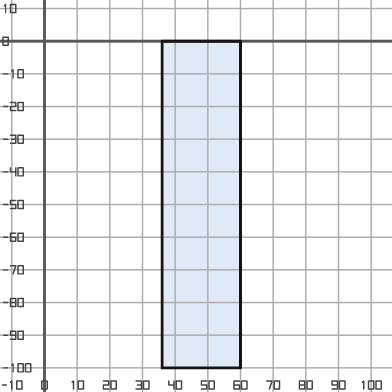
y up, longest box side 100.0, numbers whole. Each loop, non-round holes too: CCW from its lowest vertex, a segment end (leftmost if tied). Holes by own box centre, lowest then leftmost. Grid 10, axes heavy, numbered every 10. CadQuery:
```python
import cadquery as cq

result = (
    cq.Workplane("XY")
    .moveTo(36.0, -100.0)
    .lineTo(60.0, -100.0)
    .lineTo(60.0, 0.0)
    .lineTo(36.0, 0.0)
    .close()
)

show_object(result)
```